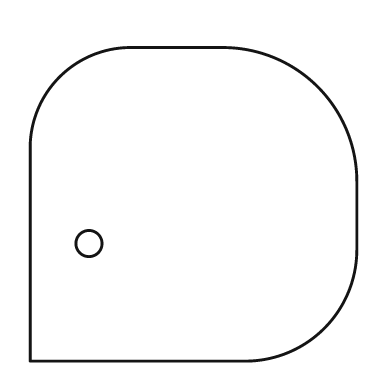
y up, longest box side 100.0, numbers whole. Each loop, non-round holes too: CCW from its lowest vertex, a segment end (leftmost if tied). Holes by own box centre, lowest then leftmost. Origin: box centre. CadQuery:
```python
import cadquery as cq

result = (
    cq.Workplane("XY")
    .moveTo(-50.0, -48.0)
    .lineTo(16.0, -48.0)
    .threePointArc((40.0, -38.0), (50.0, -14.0))
    .lineTo(50.0, 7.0)
    .threePointArc((38.0, 36.0), (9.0, 48.0))
    .lineTo(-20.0, 48.0)
    .threePointArc((-41.0, 39.0), (-50.0, 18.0))
    .close()
    .moveTo(-32.0, -12.0)
    .circle(4.0)
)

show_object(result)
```